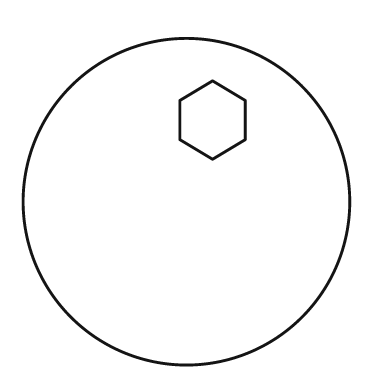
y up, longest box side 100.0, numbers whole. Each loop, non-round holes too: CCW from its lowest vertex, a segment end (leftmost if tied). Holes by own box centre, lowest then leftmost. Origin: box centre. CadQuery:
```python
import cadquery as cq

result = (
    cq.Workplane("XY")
    .moveTo(0.0, 0.0)
    .circle(50.0)
    .moveTo(8.0, 13.0)
    .lineTo(18.0, 19.0)
    .lineTo(18.0, 31.0)
    .lineTo(8.0, 37.0)
    .lineTo(-2.0, 31.0)
    .lineTo(-2.0, 19.0)
    .close()
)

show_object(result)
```